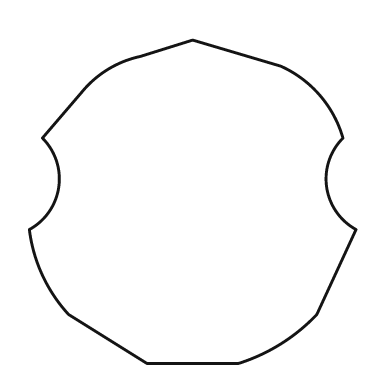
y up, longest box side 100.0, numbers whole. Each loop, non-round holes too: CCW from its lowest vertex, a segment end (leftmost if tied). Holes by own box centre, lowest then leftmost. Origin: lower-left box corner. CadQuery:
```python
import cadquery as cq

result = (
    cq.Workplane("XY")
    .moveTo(36.0, 0.0)
    .lineTo(64.0, 0.0)
    .threePointArc((77.0, 6.0), (88.0, 15.0))
    .lineTo(100.0, 41.0)
    .threePointArc((91.0, 54.0), (96.0, 69.0))
    .threePointArc((89.0, 82.0), (77.0, 91.0))
    .lineTo(50.0, 99.0)
    .lineTo(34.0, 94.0)
    .threePointArc((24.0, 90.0), (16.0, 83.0))
    .lineTo(4.0, 69.0)
    .threePointArc((9.0, 54.0), (0.0, 41.0))
    .threePointArc((4.0, 27.0), (12.0, 15.0))
    .close()
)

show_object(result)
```